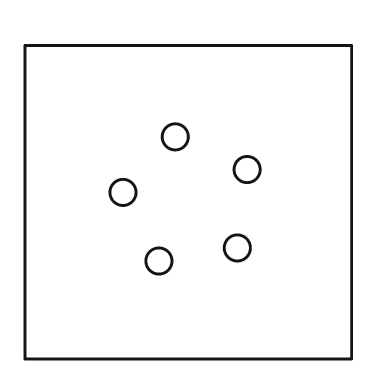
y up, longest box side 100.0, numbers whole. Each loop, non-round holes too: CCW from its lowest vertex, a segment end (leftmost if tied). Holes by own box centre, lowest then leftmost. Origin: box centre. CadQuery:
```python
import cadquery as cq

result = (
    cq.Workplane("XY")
    .moveTo(-50.0, -48.0)
    .lineTo(50.0, -48.0)
    .lineTo(50.0, 48.0)
    .lineTo(-50.0, 48.0)
    .close()
    .moveTo(-9.0, -18.0)
    .circle(4.0)
    .moveTo(15.0, -14.0)
    .circle(4.0)
    .moveTo(-20.0, 3.0)
    .circle(4.0)
    .moveTo(18.0, 10.0)
    .circle(4.0)
    .moveTo(-4.0, 20.0)
    .circle(4.0)
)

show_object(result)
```